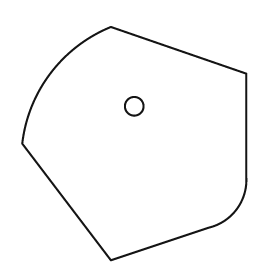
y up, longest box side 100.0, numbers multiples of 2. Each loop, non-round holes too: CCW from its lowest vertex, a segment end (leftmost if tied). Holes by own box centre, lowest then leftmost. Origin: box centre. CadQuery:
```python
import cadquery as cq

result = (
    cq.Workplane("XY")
    .moveTo(-10.0, -50.0)
    .lineTo(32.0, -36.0)
    .threePointArc((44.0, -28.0), (48.0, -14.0))
    .lineTo(48.0, 30.0)
    .lineTo(-10.0, 50.0)
    .threePointArc((-36.0, 30.0), (-48.0, 0.0))
    .close()
    .moveTo(0.0, 16.0)
    .circle(4.0)
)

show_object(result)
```